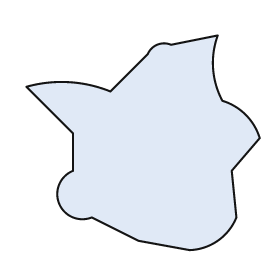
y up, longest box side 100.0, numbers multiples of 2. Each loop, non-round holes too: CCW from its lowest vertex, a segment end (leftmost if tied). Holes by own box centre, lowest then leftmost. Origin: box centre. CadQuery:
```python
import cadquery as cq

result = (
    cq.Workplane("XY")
    .moveTo(20.0, -46.0)
    .threePointArc((32.0, -42.0), (40.0, -32.0))
    .lineTo(38.0, -12.0)
    .lineTo(50.0, 2.0)
    .threePointArc((44.0, 12.0), (34.0, 18.0))
    .threePointArc((30.0, 32.0), (32.0, 46.0))
    .lineTo(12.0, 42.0)
    .threePointArc((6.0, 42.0), (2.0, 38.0))
    .lineTo(-14.0, 22.0)
    .threePointArc((-32.0, 26.0), (-50.0, 24.0))
    .lineTo(-30.0, 4.0)
    .lineTo(-30.0, -12.0)
    .threePointArc((-36.0, -26.0), (-22.0, -32.0))
    .lineTo(-2.0, -42.0)
    .close()
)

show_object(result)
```